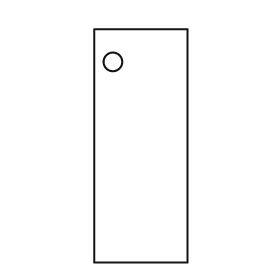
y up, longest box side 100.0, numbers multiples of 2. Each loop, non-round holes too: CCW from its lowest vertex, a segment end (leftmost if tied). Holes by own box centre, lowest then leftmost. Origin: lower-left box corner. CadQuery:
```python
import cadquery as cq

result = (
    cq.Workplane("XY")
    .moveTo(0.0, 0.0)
    .lineTo(40.0, 0.0)
    .lineTo(40.0, 100.0)
    .lineTo(0.0, 100.0)
    .close()
    .moveTo(8.0, 86.0)
    .circle(4.0)
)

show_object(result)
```